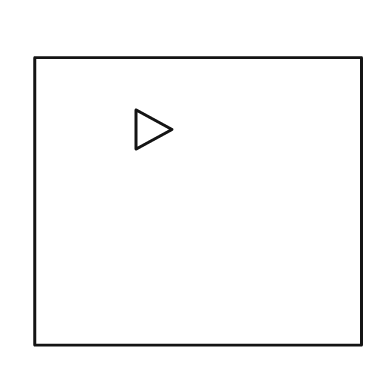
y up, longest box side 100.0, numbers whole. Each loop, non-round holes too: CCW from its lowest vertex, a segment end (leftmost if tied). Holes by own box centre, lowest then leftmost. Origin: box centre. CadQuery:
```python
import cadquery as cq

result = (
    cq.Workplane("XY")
    .moveTo(-50.0, -44.0)
    .lineTo(50.0, -44.0)
    .lineTo(50.0, 44.0)
    .lineTo(-50.0, 44.0)
    .close()
    .moveTo(-19.0, 16.0)
    .lineTo(-8.0, 22.0)
    .lineTo(-19.0, 28.0)
    .close()
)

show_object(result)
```